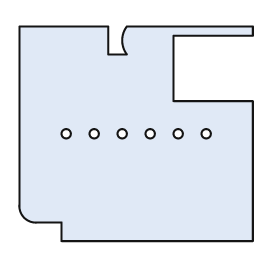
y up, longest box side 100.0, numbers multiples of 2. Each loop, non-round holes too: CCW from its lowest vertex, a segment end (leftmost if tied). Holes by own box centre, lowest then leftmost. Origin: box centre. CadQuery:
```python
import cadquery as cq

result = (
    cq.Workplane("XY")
    .moveTo(-32.0, -46.0)
    .lineTo(50.0, -46.0)
    .lineTo(50.0, 14.0)
    .lineTo(16.0, 14.0)
    .lineTo(16.0, 42.0)
    .lineTo(50.0, 42.0)
    .lineTo(50.0, 46.0)
    .lineTo(-4.0, 46.0)
    .threePointArc((-6.0, 40.0), (-4.0, 34.0))
    .lineTo(-12.0, 34.0)
    .lineTo(-12.0, 46.0)
    .lineTo(-50.0, 46.0)
    .lineTo(-50.0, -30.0)
    .threePointArc((-48.0, -36.0), (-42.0, -38.0))
    .lineTo(-32.0, -38.0)
    .close()
    .moveTo(-30.0, 0.0)
    .circle(2.0)
    .moveTo(-18.0, 0.0)
    .circle(2.0)
    .moveTo(-6.0, 0.0)
    .circle(2.0)
    .moveTo(6.0, 0.0)
    .circle(2.0)
    .moveTo(18.0, 0.0)
    .circle(2.0)
    .moveTo(30.0, 0.0)
    .circle(2.0)
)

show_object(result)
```